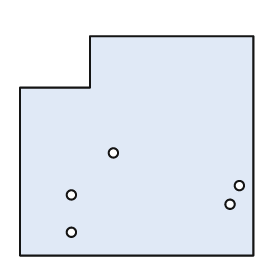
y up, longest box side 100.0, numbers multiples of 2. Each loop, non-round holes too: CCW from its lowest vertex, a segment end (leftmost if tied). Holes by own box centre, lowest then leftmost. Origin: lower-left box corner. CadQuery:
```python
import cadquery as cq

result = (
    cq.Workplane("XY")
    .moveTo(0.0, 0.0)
    .lineTo(100.0, 0.0)
    .lineTo(100.0, 94.0)
    .lineTo(30.0, 94.0)
    .lineTo(30.0, 72.0)
    .lineTo(0.0, 72.0)
    .close()
    .moveTo(22.0, 10.0)
    .circle(2.0)
    .moveTo(90.0, 22.0)
    .circle(2.0)
    .moveTo(22.0, 26.0)
    .circle(2.0)
    .moveTo(94.0, 30.0)
    .circle(2.0)
    .moveTo(40.0, 44.0)
    .circle(2.0)
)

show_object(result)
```